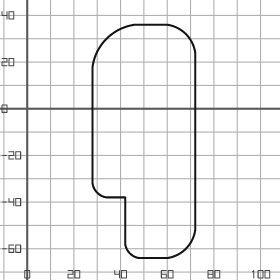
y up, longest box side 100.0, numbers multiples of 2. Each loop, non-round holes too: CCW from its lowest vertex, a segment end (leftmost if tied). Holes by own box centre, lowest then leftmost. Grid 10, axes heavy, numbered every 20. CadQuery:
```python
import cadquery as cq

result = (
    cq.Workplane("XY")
    .moveTo(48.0, -64.0)
    .lineTo(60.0, -64.0)
    .threePointArc((68.0, -60.0), (72.0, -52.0))
    .lineTo(72.0, 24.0)
    .threePointArc((68.0, 32.0), (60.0, 36.0))
    .lineTo(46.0, 36.0)
    .threePointArc((34.0, 30.0), (28.0, 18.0))
    .lineTo(28.0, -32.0)
    .threePointArc((30.0, -36.0), (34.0, -38.0))
    .lineTo(42.0, -38.0)
    .lineTo(42.0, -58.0)
    .threePointArc((44.0, -62.0), (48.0, -64.0))
    .close()
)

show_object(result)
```